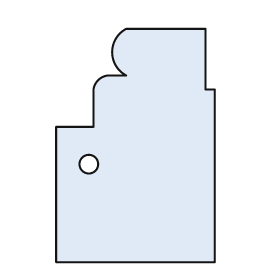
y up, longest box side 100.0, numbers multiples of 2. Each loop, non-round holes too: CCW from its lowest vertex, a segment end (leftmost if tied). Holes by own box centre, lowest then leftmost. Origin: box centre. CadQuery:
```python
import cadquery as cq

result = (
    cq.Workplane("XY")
    .moveTo(-34.0, -50.0)
    .lineTo(34.0, -50.0)
    .lineTo(34.0, 24.0)
    .lineTo(30.0, 24.0)
    .lineTo(30.0, 50.0)
    .lineTo(-4.0, 50.0)
    .threePointArc((-10.0, 40.0), (-4.0, 30.0))
    .lineTo(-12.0, 30.0)
    .threePointArc((-16.0, 28.0), (-18.0, 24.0))
    .lineTo(-18.0, 8.0)
    .lineTo(-34.0, 8.0)
    .close()
    .moveTo(-20.0, -8.0)
    .circle(4.0)
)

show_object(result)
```